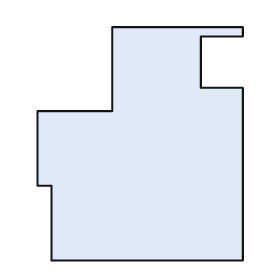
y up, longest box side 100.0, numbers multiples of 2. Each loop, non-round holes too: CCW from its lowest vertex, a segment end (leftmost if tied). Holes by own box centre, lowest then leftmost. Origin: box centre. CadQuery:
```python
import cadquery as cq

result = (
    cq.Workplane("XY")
    .moveTo(-38.0, -50.0)
    .lineTo(44.0, -50.0)
    .lineTo(44.0, 24.0)
    .lineTo(26.0, 24.0)
    .lineTo(26.0, 46.0)
    .lineTo(44.0, 46.0)
    .lineTo(44.0, 50.0)
    .lineTo(-12.0, 50.0)
    .lineTo(-12.0, 14.0)
    .lineTo(-44.0, 14.0)
    .lineTo(-44.0, -18.0)
    .lineTo(-38.0, -18.0)
    .close()
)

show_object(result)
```